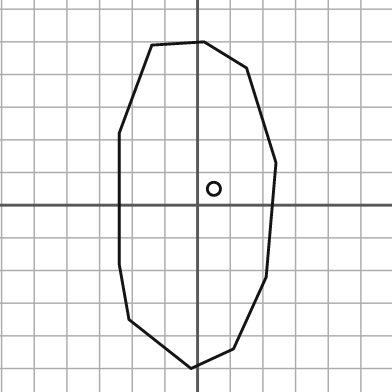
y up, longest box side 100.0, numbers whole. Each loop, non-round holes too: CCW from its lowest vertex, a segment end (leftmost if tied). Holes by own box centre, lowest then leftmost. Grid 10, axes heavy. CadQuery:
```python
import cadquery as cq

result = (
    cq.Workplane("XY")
    .moveTo(-2.0, -50.0)
    .lineTo(11.0, -44.0)
    .lineTo(21.0, -22.0)
    .lineTo(24.0, 13.0)
    .lineTo(15.0, 42.0)
    .lineTo(2.0, 50.0)
    .lineTo(-14.0, 49.0)
    .lineTo(-24.0, 22.0)
    .lineTo(-24.0, -18.0)
    .lineTo(-21.0, -35.0)
    .close()
    .moveTo(5.0, 5.0)
    .circle(2.0)
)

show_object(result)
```